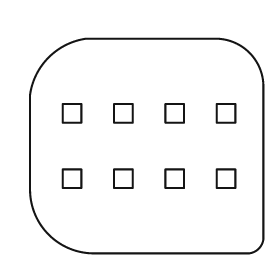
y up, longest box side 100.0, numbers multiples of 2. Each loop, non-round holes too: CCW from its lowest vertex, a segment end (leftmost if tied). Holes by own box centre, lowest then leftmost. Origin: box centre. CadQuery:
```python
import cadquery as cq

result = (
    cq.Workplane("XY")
    .moveTo(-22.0, -46.0)
    .lineTo(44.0, -46.0)
    .threePointArc((48.0, -44.0), (50.0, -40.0))
    .lineTo(50.0, 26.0)
    .threePointArc((44.0, 40.0), (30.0, 46.0))
    .lineTo(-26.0, 46.0)
    .threePointArc((-42.0, 38.0), (-50.0, 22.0))
    .lineTo(-50.0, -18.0)
    .threePointArc((-42.0, -38.0), (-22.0, -46.0))
    .close()
    .moveTo(-36.0, -18.0)
    .lineTo(-28.0, -18.0)
    .lineTo(-28.0, -10.0)
    .lineTo(-36.0, -10.0)
    .close()
    .moveTo(-14.0, -18.0)
    .lineTo(-6.0, -18.0)
    .lineTo(-6.0, -10.0)
    .lineTo(-14.0, -10.0)
    .close()
    .moveTo(8.0, -18.0)
    .lineTo(16.0, -18.0)
    .lineTo(16.0, -10.0)
    .lineTo(8.0, -10.0)
    .close()
    .moveTo(30.0, -18.0)
    .lineTo(38.0, -18.0)
    .lineTo(38.0, -10.0)
    .lineTo(30.0, -10.0)
    .close()
    .moveTo(-36.0, 10.0)
    .lineTo(-28.0, 10.0)
    .lineTo(-28.0, 18.0)
    .lineTo(-36.0, 18.0)
    .close()
    .moveTo(-14.0, 10.0)
    .lineTo(-6.0, 10.0)
    .lineTo(-6.0, 18.0)
    .lineTo(-14.0, 18.0)
    .close()
    .moveTo(8.0, 10.0)
    .lineTo(16.0, 10.0)
    .lineTo(16.0, 18.0)
    .lineTo(8.0, 18.0)
    .close()
    .moveTo(30.0, 10.0)
    .lineTo(38.0, 10.0)
    .lineTo(38.0, 18.0)
    .lineTo(30.0, 18.0)
    .close()
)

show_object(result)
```